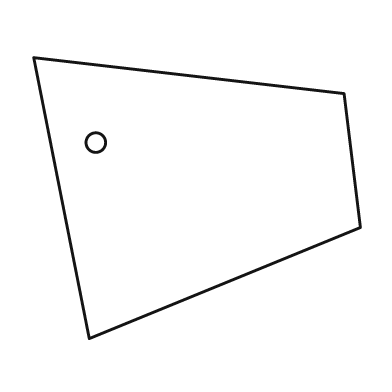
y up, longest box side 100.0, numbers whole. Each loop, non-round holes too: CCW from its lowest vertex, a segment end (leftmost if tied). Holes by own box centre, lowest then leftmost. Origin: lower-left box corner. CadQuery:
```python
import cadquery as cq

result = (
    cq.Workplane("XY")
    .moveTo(17.0, 0.0)
    .lineTo(100.0, 34.0)
    .lineTo(95.0, 75.0)
    .lineTo(0.0, 86.0)
    .close()
    .moveTo(19.0, 60.0)
    .circle(3.0)
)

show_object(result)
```